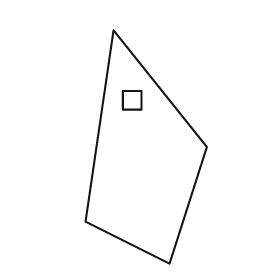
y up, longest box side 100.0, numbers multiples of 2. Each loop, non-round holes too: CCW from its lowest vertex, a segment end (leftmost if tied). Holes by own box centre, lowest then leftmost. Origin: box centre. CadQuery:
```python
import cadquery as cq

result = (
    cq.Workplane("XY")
    .moveTo(10.0, -50.0)
    .lineTo(26.0, 0.0)
    .lineTo(-14.0, 50.0)
    .lineTo(-26.0, -32.0)
    .close()
    .moveTo(-10.0, 16.0)
    .lineTo(-2.0, 16.0)
    .lineTo(-2.0, 24.0)
    .lineTo(-10.0, 24.0)
    .close()
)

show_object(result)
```